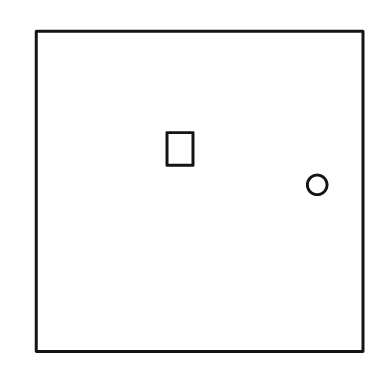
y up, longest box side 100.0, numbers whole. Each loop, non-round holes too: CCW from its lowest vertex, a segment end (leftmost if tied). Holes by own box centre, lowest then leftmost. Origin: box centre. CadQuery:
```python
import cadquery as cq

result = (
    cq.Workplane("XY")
    .moveTo(-50.0, -49.0)
    .lineTo(50.0, -49.0)
    .lineTo(50.0, 49.0)
    .lineTo(-50.0, 49.0)
    .close()
    .moveTo(36.0, 2.0)
    .circle(3.0)
    .moveTo(-10.0, 8.0)
    .lineTo(-2.0, 8.0)
    .lineTo(-2.0, 18.0)
    .lineTo(-10.0, 18.0)
    .close()
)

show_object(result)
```